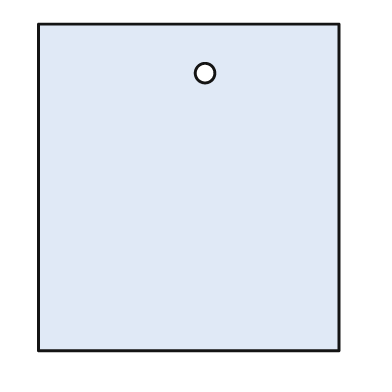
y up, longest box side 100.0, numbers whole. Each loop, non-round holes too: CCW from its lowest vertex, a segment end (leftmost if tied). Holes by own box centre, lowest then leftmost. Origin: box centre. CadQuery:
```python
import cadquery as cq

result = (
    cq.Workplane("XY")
    .moveTo(-46.0, -50.0)
    .lineTo(46.0, -50.0)
    .lineTo(46.0, 50.0)
    .lineTo(-46.0, 50.0)
    .close()
    .moveTo(5.0, 35.0)
    .circle(3.0)
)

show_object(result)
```